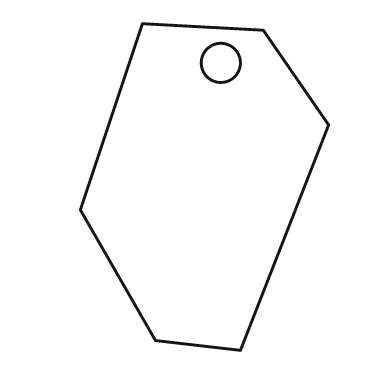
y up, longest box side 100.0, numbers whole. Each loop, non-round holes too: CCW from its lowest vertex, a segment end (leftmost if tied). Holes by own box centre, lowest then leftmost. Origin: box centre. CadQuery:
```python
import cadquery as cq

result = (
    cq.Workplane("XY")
    .moveTo(11.0, -50.0)
    .lineTo(38.0, 19.0)
    .lineTo(18.0, 48.0)
    .lineTo(-19.0, 50.0)
    .lineTo(-38.0, -7.0)
    .lineTo(-15.0, -47.0)
    .close()
    .moveTo(5.0, 38.0)
    .circle(6.0)
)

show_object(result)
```